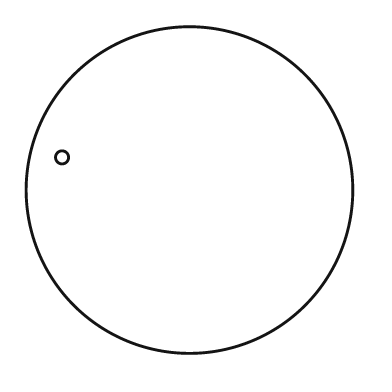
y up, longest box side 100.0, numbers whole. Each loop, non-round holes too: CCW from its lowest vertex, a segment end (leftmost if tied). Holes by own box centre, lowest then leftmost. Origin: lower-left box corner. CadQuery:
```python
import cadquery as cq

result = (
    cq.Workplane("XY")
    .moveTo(50.0, 50.0)
    .circle(50.0)
    .moveTo(11.0, 60.0)
    .circle(2.0)
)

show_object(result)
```